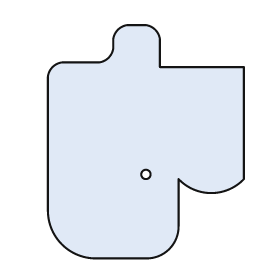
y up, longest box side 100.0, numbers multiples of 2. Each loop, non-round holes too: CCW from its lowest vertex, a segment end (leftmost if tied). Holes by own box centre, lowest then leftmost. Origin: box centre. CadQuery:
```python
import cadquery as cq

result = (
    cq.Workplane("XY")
    .moveTo(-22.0, -50.0)
    .lineTo(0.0, -50.0)
    .threePointArc((10.0, -46.0), (14.0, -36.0))
    .lineTo(14.0, -16.0)
    .threePointArc((28.0, -22.0), (42.0, -16.0))
    .lineTo(42.0, 32.0)
    .lineTo(6.0, 32.0)
    .lineTo(6.0, 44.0)
    .threePointArc((4.0, 48.0), (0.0, 50.0))
    .lineTo(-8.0, 50.0)
    .threePointArc((-12.0, 48.0), (-14.0, 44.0))
    .lineTo(-14.0, 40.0)
    .threePointArc((-16.0, 36.0), (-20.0, 34.0))
    .lineTo(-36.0, 34.0)
    .threePointArc((-40.0, 32.0), (-42.0, 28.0))
    .lineTo(-42.0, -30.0)
    .threePointArc((-36.0, -44.0), (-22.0, -50.0))
    .close()
    .moveTo(0.0, -14.0)
    .circle(2.0)
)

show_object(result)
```